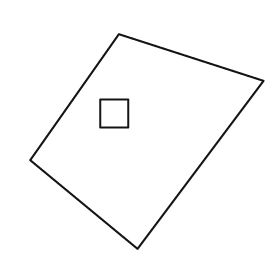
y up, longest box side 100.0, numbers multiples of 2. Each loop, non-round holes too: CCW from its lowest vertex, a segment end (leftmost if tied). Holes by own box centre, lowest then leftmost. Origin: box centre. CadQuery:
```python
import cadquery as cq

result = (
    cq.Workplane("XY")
    .moveTo(-4.0, -46.0)
    .lineTo(50.0, 26.0)
    .lineTo(-12.0, 46.0)
    .lineTo(-50.0, -8.0)
    .close()
    .moveTo(-20.0, 6.0)
    .lineTo(-8.0, 6.0)
    .lineTo(-8.0, 18.0)
    .lineTo(-20.0, 18.0)
    .close()
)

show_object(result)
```